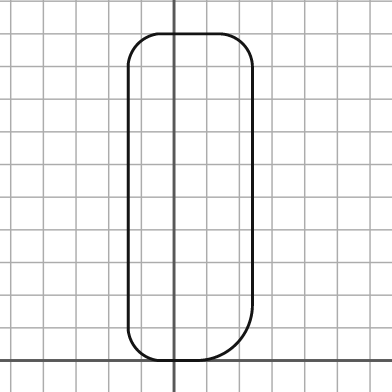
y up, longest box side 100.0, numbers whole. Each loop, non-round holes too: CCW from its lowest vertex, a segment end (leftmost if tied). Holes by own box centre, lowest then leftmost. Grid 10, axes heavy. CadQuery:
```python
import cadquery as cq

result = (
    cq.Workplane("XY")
    .moveTo(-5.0, 0.0)
    .lineTo(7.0, 0.0)
    .threePointArc((19.0, 5.0), (24.0, 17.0))
    .lineTo(24.0, 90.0)
    .threePointArc((21.0, 97.0), (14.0, 100.0))
    .lineTo(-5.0, 100.0)
    .threePointArc((-11.0, 97.0), (-14.0, 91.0))
    .lineTo(-14.0, 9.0)
    .threePointArc((-11.0, 3.0), (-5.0, 0.0))
    .close()
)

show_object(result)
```